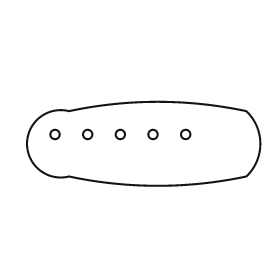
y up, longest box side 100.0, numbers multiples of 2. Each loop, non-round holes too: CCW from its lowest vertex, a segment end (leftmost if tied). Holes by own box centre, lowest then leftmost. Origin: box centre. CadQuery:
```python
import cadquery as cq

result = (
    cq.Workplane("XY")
    .moveTo(-32.0, -14.0)
    .threePointArc((6.0, -18.0), (44.0, -14.0))
    .threePointArc((50.0, 0.0), (44.0, 14.0))
    .threePointArc((6.0, 18.0), (-32.0, 14.0))
    .threePointArc((-50.0, 0.0), (-32.0, -14.0))
    .close()
    .moveTo(-38.0, 4.0)
    .circle(2.0)
    .moveTo(-24.0, 4.0)
    .circle(2.0)
    .moveTo(-10.0, 4.0)
    .circle(2.0)
    .moveTo(4.0, 4.0)
    .circle(2.0)
    .moveTo(18.0, 4.0)
    .circle(2.0)
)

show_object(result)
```